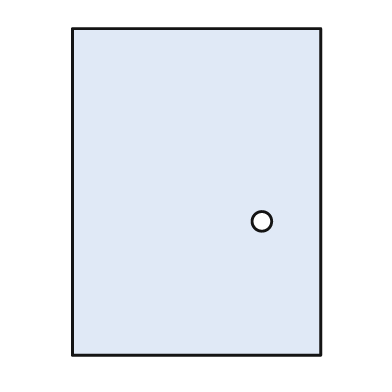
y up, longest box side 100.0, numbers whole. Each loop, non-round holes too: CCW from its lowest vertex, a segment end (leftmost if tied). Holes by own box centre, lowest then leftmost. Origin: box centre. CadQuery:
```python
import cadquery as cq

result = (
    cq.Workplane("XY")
    .moveTo(-38.0, -50.0)
    .lineTo(38.0, -50.0)
    .lineTo(38.0, 50.0)
    .lineTo(-38.0, 50.0)
    .close()
    .moveTo(20.0, -9.0)
    .circle(3.0)
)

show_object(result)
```